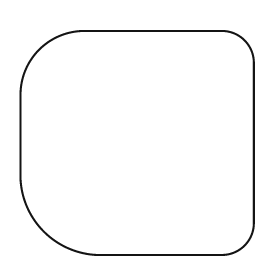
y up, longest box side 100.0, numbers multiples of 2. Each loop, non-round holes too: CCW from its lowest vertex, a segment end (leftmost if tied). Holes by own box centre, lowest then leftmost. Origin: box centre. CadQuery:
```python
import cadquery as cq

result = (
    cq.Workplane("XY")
    .moveTo(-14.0, -48.0)
    .lineTo(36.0, -48.0)
    .threePointArc((46.0, -44.0), (50.0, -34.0))
    .lineTo(50.0, 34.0)
    .threePointArc((46.0, 44.0), (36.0, 48.0))
    .lineTo(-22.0, 48.0)
    .threePointArc((-42.0, 40.0), (-50.0, 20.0))
    .lineTo(-50.0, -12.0)
    .threePointArc((-40.0, -38.0), (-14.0, -48.0))
    .close()
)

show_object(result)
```